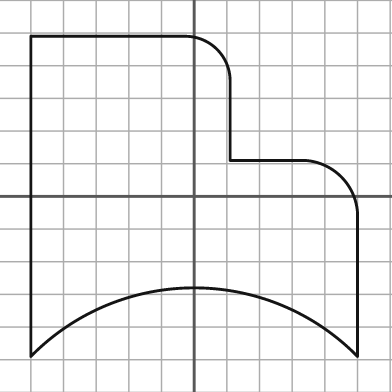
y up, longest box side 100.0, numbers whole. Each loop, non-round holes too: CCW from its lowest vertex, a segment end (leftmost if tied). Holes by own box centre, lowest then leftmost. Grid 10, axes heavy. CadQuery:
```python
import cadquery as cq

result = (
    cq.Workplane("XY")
    .moveTo(-50.0, -49.0)
    .threePointArc((0.0, -28.0), (50.0, -49.0))
    .lineTo(50.0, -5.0)
    .threePointArc((45.0, 6.0), (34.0, 11.0))
    .lineTo(11.0, 11.0)
    .lineTo(11.0, 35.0)
    .threePointArc((7.0, 45.0), (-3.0, 49.0))
    .lineTo(-50.0, 49.0)
    .close()
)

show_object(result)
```